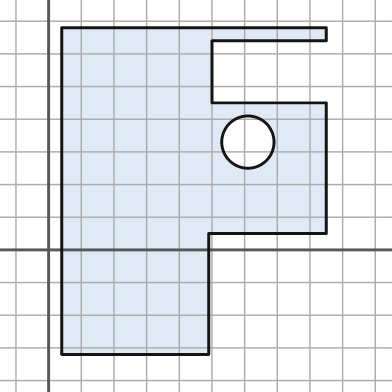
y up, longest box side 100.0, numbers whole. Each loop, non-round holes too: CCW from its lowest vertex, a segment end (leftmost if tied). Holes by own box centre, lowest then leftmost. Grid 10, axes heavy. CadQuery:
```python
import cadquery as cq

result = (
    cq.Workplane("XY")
    .moveTo(4.0, -32.0)
    .lineTo(49.0, -32.0)
    .lineTo(49.0, 5.0)
    .lineTo(85.0, 5.0)
    .lineTo(85.0, 45.0)
    .lineTo(50.0, 45.0)
    .lineTo(50.0, 64.0)
    .lineTo(85.0, 64.0)
    .lineTo(85.0, 68.0)
    .lineTo(4.0, 68.0)
    .close()
    .moveTo(61.0, 33.0)
    .circle(8.0)
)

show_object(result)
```